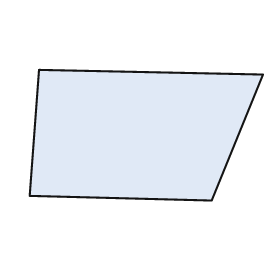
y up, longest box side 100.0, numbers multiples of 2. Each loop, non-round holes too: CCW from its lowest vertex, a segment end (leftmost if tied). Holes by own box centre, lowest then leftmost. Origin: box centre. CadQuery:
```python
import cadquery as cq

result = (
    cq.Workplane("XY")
    .moveTo(28.0, -28.0)
    .lineTo(50.0, 26.0)
    .lineTo(-46.0, 28.0)
    .lineTo(-50.0, -26.0)
    .close()
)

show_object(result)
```